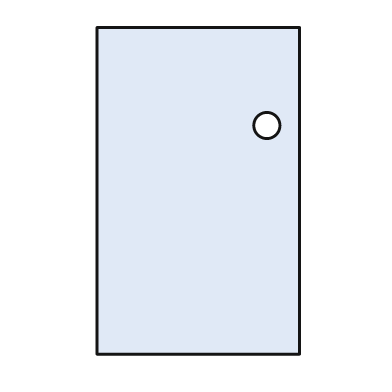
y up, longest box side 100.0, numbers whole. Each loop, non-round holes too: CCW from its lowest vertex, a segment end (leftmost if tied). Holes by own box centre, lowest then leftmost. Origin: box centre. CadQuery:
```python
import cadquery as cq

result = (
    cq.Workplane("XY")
    .moveTo(-31.0, -50.0)
    .lineTo(31.0, -50.0)
    .lineTo(31.0, 50.0)
    .lineTo(-31.0, 50.0)
    .close()
    .moveTo(21.0, 20.0)
    .circle(4.0)
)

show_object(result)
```